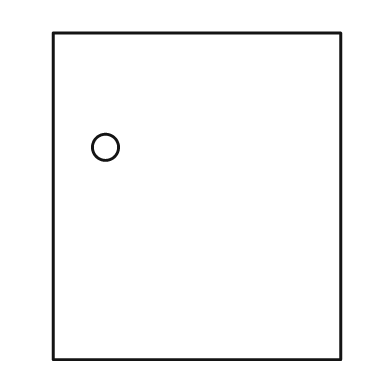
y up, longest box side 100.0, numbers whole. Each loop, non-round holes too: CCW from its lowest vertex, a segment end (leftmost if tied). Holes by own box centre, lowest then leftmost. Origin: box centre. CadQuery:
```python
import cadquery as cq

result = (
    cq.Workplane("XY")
    .moveTo(-44.0, -50.0)
    .lineTo(44.0, -50.0)
    .lineTo(44.0, 50.0)
    .lineTo(-44.0, 50.0)
    .close()
    .moveTo(-28.0, 15.0)
    .circle(4.0)
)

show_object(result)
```